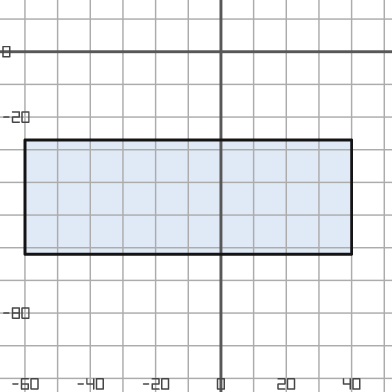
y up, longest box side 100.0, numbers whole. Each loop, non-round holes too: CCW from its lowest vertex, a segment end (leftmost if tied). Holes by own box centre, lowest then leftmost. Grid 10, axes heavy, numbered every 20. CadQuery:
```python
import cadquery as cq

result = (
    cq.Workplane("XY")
    .moveTo(-60.0, -62.0)
    .lineTo(40.0, -62.0)
    .lineTo(40.0, -27.0)
    .lineTo(-60.0, -27.0)
    .close()
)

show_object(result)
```